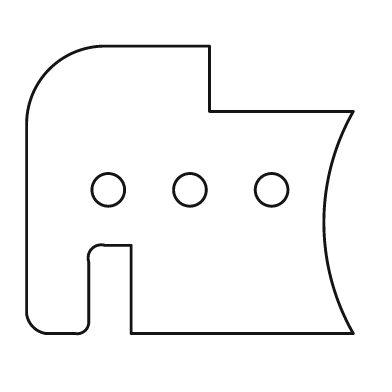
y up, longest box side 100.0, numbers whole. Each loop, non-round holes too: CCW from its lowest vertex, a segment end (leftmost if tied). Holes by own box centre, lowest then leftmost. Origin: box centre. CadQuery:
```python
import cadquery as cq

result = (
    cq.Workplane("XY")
    .moveTo(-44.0, -44.0)
    .lineTo(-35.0, -44.0)
    .threePointArc((-32.0, -43.0), (-31.0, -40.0))
    .lineTo(-31.0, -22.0)
    .threePointArc((-30.0, -18.0), (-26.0, -17.0))
    .lineTo(-18.0, -17.0)
    .lineTo(-18.0, -44.0)
    .lineTo(50.0, -44.0)
    .threePointArc((41.0, -10.0), (50.0, 24.0))
    .lineTo(6.0, 24.0)
    .lineTo(6.0, 44.0)
    .lineTo(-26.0, 44.0)
    .threePointArc((-43.0, 37.0), (-50.0, 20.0))
    .lineTo(-50.0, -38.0)
    .threePointArc((-48.0, -42.0), (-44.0, -44.0))
    .close()
    .moveTo(-25.0, 0.0)
    .circle(5.0)
    .moveTo(0.0, 0.0)
    .circle(5.0)
    .moveTo(25.0, 0.0)
    .circle(5.0)
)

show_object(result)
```